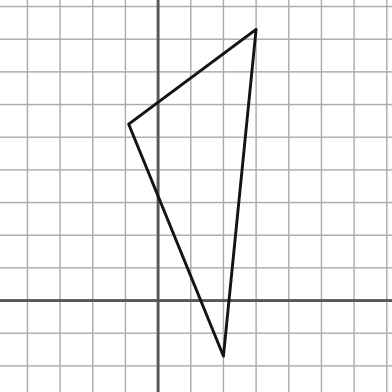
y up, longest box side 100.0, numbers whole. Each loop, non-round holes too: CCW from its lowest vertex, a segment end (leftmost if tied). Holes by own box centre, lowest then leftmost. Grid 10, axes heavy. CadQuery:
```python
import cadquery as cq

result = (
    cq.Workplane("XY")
    .moveTo(20.0, -17.0)
    .lineTo(30.0, 83.0)
    .lineTo(-9.0, 54.0)
    .close()
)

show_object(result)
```